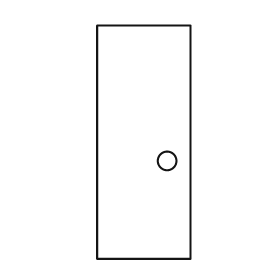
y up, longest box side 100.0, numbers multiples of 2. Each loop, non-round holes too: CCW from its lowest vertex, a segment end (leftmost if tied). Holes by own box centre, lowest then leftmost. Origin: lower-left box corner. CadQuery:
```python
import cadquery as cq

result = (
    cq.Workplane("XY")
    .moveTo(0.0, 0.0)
    .lineTo(40.0, 0.0)
    .lineTo(40.0, 100.0)
    .lineTo(0.0, 100.0)
    .close()
    .moveTo(30.0, 42.0)
    .circle(4.0)
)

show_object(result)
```